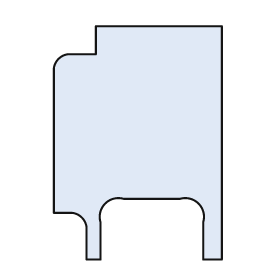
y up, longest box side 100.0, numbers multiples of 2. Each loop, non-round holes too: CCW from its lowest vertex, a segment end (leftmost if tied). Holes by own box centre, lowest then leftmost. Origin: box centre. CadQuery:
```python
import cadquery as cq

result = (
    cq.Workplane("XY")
    .moveTo(-22.0, -50.0)
    .lineTo(-16.0, -50.0)
    .lineTo(-16.0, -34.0)
    .threePointArc((-14.0, -26.0), (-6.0, -24.0))
    .lineTo(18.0, -24.0)
    .threePointArc((26.0, -26.0), (28.0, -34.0))
    .lineTo(28.0, -50.0)
    .lineTo(36.0, -50.0)
    .lineTo(36.0, 50.0)
    .lineTo(-18.0, 50.0)
    .lineTo(-18.0, 38.0)
    .lineTo(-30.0, 38.0)
    .threePointArc((-34.0, 36.0), (-36.0, 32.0))
    .lineTo(-36.0, -30.0)
    .lineTo(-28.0, -30.0)
    .threePointArc((-24.0, -32.0), (-22.0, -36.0))
    .close()
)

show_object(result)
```